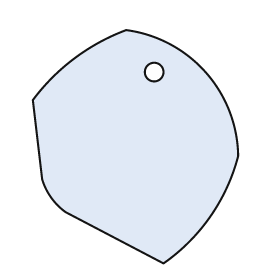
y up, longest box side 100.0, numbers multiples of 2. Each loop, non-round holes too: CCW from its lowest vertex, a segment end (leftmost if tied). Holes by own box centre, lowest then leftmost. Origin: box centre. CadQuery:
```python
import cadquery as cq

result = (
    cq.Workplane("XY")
    .moveTo(12.0, -50.0)
    .threePointArc((32.0, -30.0), (44.0, -4.0))
    .threePointArc((30.0, 32.0), (-4.0, 50.0))
    .threePointArc((-26.0, 38.0), (-44.0, 20.0))
    .lineTo(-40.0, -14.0)
    .threePointArc((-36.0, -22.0), (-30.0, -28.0))
    .close()
    .moveTo(8.0, 32.0)
    .circle(4.0)
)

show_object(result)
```